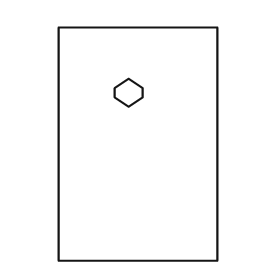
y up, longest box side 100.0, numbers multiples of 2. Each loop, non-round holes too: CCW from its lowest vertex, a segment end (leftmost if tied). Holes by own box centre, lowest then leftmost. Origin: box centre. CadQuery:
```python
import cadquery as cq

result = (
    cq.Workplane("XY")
    .moveTo(-34.0, -50.0)
    .lineTo(34.0, -50.0)
    .lineTo(34.0, 50.0)
    .lineTo(-34.0, 50.0)
    .close()
    .moveTo(-4.0, 16.0)
    .lineTo(2.0, 20.0)
    .lineTo(2.0, 24.0)
    .lineTo(-4.0, 28.0)
    .lineTo(-10.0, 24.0)
    .lineTo(-10.0, 20.0)
    .close()
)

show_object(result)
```